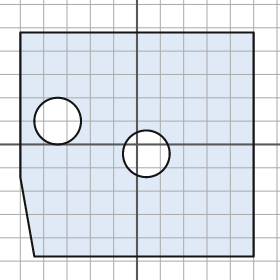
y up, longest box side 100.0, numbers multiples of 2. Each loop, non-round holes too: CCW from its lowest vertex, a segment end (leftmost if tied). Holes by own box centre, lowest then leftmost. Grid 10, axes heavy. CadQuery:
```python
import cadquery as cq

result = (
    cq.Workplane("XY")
    .moveTo(-44.0, -48.0)
    .lineTo(50.0, -48.0)
    .lineTo(50.0, 48.0)
    .lineTo(-50.0, 48.0)
    .lineTo(-50.0, -14.0)
    .close()
    .moveTo(4.0, -4.0)
    .circle(10.0)
    .moveTo(-34.0, 10.0)
    .circle(10.0)
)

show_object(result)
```